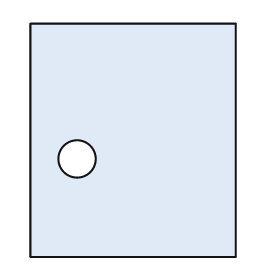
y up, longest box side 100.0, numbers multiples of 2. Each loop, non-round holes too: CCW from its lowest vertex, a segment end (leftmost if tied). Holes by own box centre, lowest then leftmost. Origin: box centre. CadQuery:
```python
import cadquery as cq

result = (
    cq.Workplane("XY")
    .moveTo(-44.0, -50.0)
    .lineTo(44.0, -50.0)
    .lineTo(44.0, 50.0)
    .lineTo(-44.0, 50.0)
    .close()
    .moveTo(-24.0, -8.0)
    .circle(8.0)
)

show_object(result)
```